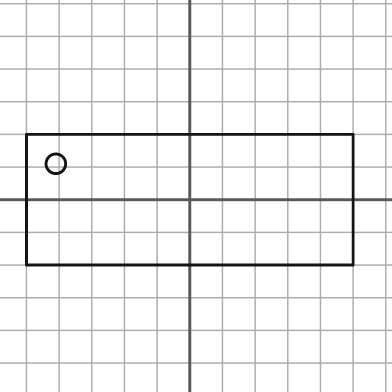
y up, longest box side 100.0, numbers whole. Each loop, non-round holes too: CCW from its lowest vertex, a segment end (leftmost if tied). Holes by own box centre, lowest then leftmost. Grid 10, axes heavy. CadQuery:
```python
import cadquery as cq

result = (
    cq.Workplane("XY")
    .moveTo(-50.0, -20.0)
    .lineTo(50.0, -20.0)
    .lineTo(50.0, 20.0)
    .lineTo(-50.0, 20.0)
    .close()
    .moveTo(-41.0, 11.0)
    .circle(3.0)
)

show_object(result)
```